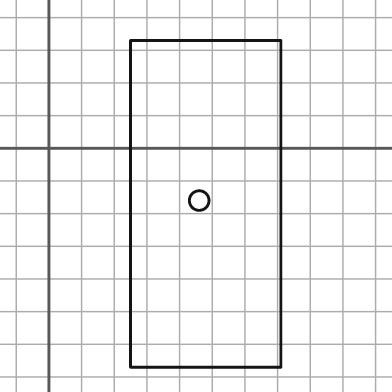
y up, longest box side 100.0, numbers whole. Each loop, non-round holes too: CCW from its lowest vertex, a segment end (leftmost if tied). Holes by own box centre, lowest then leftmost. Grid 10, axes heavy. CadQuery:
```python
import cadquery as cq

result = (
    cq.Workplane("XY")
    .moveTo(25.0, -67.0)
    .lineTo(71.0, -67.0)
    .lineTo(71.0, 33.0)
    .lineTo(25.0, 33.0)
    .close()
    .moveTo(46.0, -16.0)
    .circle(3.0)
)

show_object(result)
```